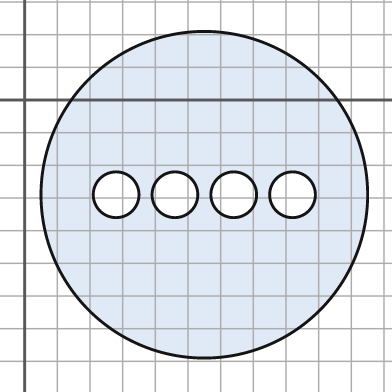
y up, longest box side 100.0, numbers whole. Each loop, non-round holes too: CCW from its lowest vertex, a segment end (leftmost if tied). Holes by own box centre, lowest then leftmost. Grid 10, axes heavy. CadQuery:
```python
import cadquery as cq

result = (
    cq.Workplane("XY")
    .moveTo(55.0, -29.0)
    .circle(50.0)
    .moveTo(28.0, -29.0)
    .circle(7.0)
    .moveTo(46.0, -29.0)
    .circle(7.0)
    .moveTo(64.0, -29.0)
    .circle(7.0)
    .moveTo(82.0, -29.0)
    .circle(7.0)
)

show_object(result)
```